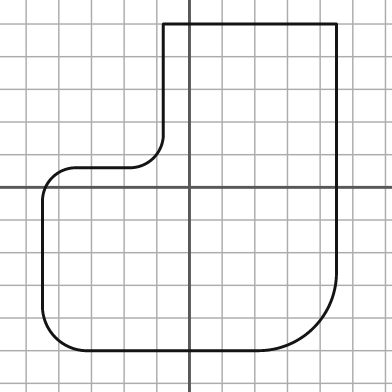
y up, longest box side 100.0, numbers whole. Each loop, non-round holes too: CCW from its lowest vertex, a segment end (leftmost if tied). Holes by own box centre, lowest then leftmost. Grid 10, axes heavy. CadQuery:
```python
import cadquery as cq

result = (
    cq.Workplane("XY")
    .moveTo(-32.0, -50.0)
    .lineTo(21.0, -50.0)
    .threePointArc((38.0, -43.0), (45.0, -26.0))
    .lineTo(45.0, 50.0)
    .lineTo(-8.0, 50.0)
    .lineTo(-8.0, 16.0)
    .threePointArc((-11.0, 9.0), (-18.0, 6.0))
    .lineTo(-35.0, 6.0)
    .threePointArc((-42.0, 3.0), (-45.0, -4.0))
    .lineTo(-45.0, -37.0)
    .threePointArc((-41.0, -46.0), (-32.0, -50.0))
    .close()
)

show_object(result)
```